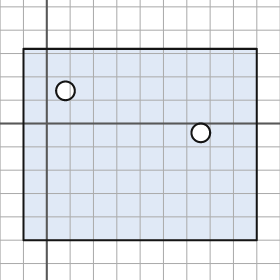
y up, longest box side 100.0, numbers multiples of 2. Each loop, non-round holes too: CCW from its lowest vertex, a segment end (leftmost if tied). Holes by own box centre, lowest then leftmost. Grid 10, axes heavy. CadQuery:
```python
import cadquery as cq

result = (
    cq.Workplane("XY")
    .moveTo(-10.0, -50.0)
    .lineTo(90.0, -50.0)
    .lineTo(90.0, 32.0)
    .lineTo(-10.0, 32.0)
    .close()
    .moveTo(66.0, -4.0)
    .circle(4.0)
    .moveTo(8.0, 14.0)
    .circle(4.0)
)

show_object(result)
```